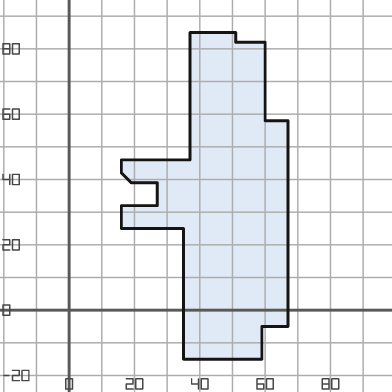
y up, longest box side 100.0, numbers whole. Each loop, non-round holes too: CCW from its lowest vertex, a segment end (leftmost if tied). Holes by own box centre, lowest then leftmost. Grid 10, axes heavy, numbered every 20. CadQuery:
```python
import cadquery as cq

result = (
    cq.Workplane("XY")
    .moveTo(35.0, -15.0)
    .lineTo(59.0, -15.0)
    .lineTo(59.0, -5.0)
    .lineTo(67.0, -5.0)
    .lineTo(67.0, 58.0)
    .lineTo(60.0, 58.0)
    .lineTo(60.0, 82.0)
    .lineTo(51.0, 82.0)
    .lineTo(51.0, 85.0)
    .lineTo(37.0, 85.0)
    .lineTo(37.0, 46.0)
    .lineTo(16.0, 46.0)
    .lineTo(16.0, 42.0)
    .lineTo(19.0, 39.0)
    .lineTo(27.0, 39.0)
    .lineTo(27.0, 32.0)
    .lineTo(16.0, 32.0)
    .lineTo(16.0, 25.0)
    .lineTo(35.0, 25.0)
    .close()
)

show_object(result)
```